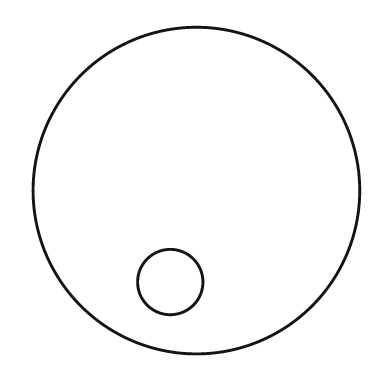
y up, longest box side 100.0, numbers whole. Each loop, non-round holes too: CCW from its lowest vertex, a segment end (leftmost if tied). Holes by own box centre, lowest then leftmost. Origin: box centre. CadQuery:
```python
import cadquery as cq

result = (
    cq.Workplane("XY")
    .moveTo(0.0, 0.0)
    .circle(50.0)
    .moveTo(-8.0, -28.0)
    .circle(10.0)
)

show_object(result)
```